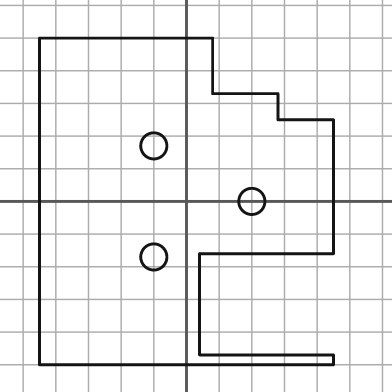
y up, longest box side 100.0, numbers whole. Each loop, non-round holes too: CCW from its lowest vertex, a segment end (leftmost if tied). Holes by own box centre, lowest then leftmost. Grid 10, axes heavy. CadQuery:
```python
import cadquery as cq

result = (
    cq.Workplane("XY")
    .moveTo(-45.0, -50.0)
    .lineTo(45.0, -50.0)
    .lineTo(45.0, -47.0)
    .lineTo(4.0, -47.0)
    .lineTo(4.0, -16.0)
    .lineTo(45.0, -16.0)
    .lineTo(45.0, 25.0)
    .lineTo(28.0, 25.0)
    .lineTo(28.0, 33.0)
    .lineTo(8.0, 33.0)
    .lineTo(8.0, 50.0)
    .lineTo(-45.0, 50.0)
    .close()
    .moveTo(-10.0, -17.0)
    .circle(4.0)
    .moveTo(20.0, 0.0)
    .circle(4.0)
    .moveTo(-10.0, 17.0)
    .circle(4.0)
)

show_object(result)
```